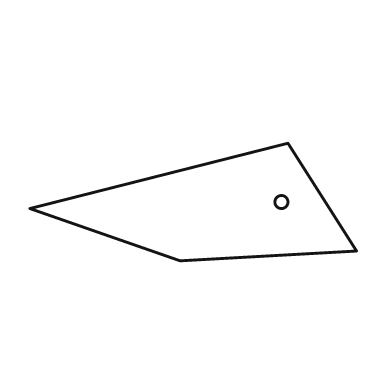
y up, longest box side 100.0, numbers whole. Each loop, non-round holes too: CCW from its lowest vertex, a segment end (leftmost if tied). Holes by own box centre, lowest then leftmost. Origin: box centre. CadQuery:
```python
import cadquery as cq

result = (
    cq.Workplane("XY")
    .moveTo(-4.0, -18.0)
    .lineTo(50.0, -15.0)
    .lineTo(29.0, 18.0)
    .lineTo(-50.0, -2.0)
    .close()
    .moveTo(27.0, 0.0)
    .circle(2.0)
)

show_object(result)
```